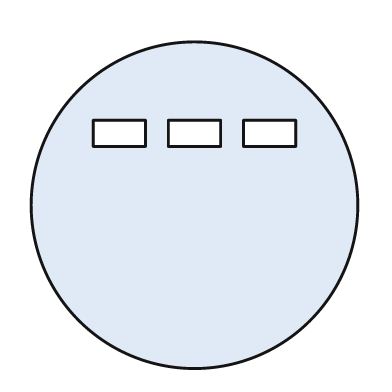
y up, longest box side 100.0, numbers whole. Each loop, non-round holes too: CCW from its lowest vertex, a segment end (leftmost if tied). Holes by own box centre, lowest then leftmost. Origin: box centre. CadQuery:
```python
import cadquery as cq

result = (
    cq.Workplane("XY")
    .moveTo(0.0, 0.0)
    .circle(50.0)
    .moveTo(-31.0, 18.0)
    .lineTo(-15.0, 18.0)
    .lineTo(-15.0, 26.0)
    .lineTo(-31.0, 26.0)
    .close()
    .moveTo(-8.0, 18.0)
    .lineTo(8.0, 18.0)
    .lineTo(8.0, 26.0)
    .lineTo(-8.0, 26.0)
    .close()
    .moveTo(15.0, 18.0)
    .lineTo(31.0, 18.0)
    .lineTo(31.0, 26.0)
    .lineTo(15.0, 26.0)
    .close()
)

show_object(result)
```